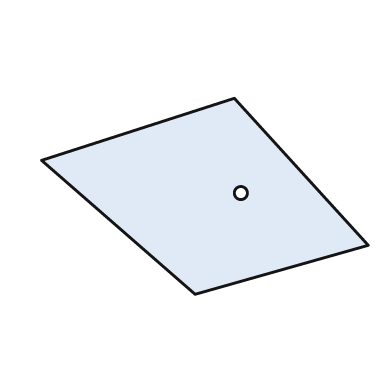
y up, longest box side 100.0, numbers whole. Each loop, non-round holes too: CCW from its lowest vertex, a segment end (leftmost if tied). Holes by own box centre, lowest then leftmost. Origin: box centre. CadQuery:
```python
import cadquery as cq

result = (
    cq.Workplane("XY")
    .moveTo(-3.0, -30.0)
    .lineTo(50.0, -15.0)
    .lineTo(9.0, 30.0)
    .lineTo(-50.0, 11.0)
    .close()
    .moveTo(11.0, 1.0)
    .circle(2.0)
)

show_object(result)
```